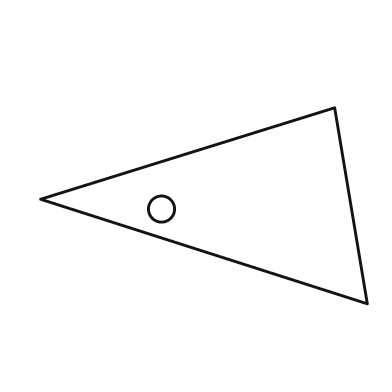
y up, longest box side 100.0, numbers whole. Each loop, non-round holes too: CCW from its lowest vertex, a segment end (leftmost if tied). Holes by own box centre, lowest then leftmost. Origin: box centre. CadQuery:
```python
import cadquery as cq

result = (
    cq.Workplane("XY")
    .moveTo(50.0, -30.0)
    .lineTo(40.0, 30.0)
    .lineTo(-50.0, 2.0)
    .close()
    .moveTo(-13.0, -1.0)
    .circle(4.0)
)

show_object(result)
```